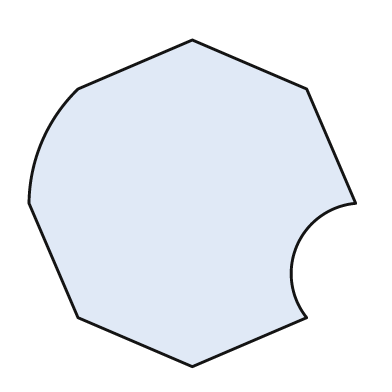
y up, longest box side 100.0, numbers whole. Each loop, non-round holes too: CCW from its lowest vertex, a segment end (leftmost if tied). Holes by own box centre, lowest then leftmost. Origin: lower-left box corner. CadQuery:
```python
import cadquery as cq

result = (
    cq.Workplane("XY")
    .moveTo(50.0, 0.0)
    .lineTo(85.0, 15.0)
    .threePointArc((82.0, 37.0), (100.0, 50.0))
    .lineTo(85.0, 85.0)
    .lineTo(50.0, 100.0)
    .lineTo(15.0, 85.0)
    .threePointArc((4.0, 69.0), (0.0, 50.0))
    .lineTo(15.0, 15.0)
    .close()
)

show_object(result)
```